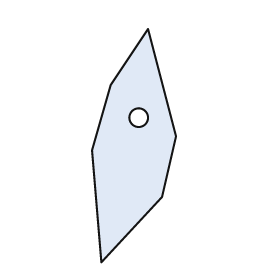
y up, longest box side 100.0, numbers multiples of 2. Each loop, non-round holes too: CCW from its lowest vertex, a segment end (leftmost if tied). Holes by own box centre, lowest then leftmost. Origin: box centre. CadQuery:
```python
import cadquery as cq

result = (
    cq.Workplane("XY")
    .moveTo(-14.0, -50.0)
    .lineTo(12.0, -22.0)
    .lineTo(18.0, 4.0)
    .lineTo(6.0, 50.0)
    .lineTo(-10.0, 26.0)
    .lineTo(-18.0, -2.0)
    .close()
    .moveTo(2.0, 12.0)
    .circle(4.0)
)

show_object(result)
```